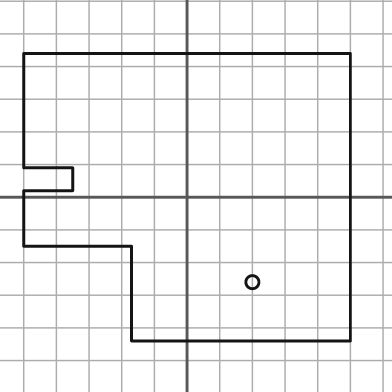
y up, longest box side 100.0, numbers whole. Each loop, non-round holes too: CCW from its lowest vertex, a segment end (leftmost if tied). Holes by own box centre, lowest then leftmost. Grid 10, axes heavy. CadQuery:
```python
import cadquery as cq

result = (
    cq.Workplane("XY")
    .moveTo(-17.0, -44.0)
    .lineTo(50.0, -44.0)
    .lineTo(50.0, 44.0)
    .lineTo(-50.0, 44.0)
    .lineTo(-50.0, 9.0)
    .lineTo(-35.0, 9.0)
    .lineTo(-35.0, 2.0)
    .lineTo(-50.0, 2.0)
    .lineTo(-50.0, -15.0)
    .lineTo(-17.0, -15.0)
    .close()
    .moveTo(20.0, -26.0)
    .circle(2.0)
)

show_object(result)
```